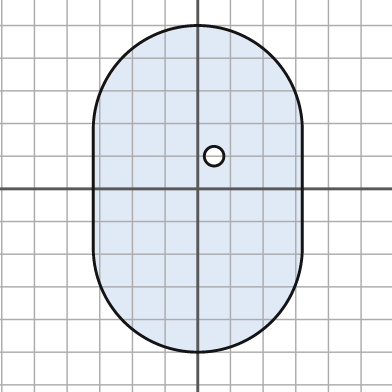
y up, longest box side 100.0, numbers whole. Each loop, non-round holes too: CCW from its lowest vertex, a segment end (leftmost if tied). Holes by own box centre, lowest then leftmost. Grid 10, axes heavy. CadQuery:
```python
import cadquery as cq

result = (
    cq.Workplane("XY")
    .moveTo(-32.0, -18.0)
    .threePointArc((0.0, -50.0), (32.0, -18.0))
    .lineTo(32.0, 18.0)
    .threePointArc((0.0, 50.0), (-32.0, 18.0))
    .close()
    .moveTo(5.0, 10.0)
    .circle(3.0)
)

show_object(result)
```